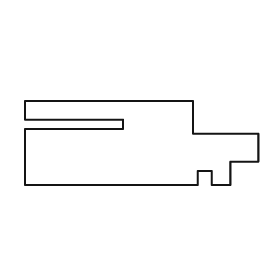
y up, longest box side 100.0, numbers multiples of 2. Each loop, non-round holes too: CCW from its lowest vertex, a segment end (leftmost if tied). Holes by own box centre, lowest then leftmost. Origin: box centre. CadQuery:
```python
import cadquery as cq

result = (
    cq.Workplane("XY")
    .moveTo(-50.0, -18.0)
    .lineTo(24.0, -18.0)
    .lineTo(24.0, -12.0)
    .lineTo(30.0, -12.0)
    .lineTo(30.0, -18.0)
    .lineTo(38.0, -18.0)
    .lineTo(38.0, -8.0)
    .lineTo(50.0, -8.0)
    .lineTo(50.0, 4.0)
    .lineTo(22.0, 4.0)
    .lineTo(22.0, 18.0)
    .lineTo(-50.0, 18.0)
    .lineTo(-50.0, 10.0)
    .lineTo(-8.0, 10.0)
    .lineTo(-8.0, 6.0)
    .lineTo(-50.0, 6.0)
    .close()
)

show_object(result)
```